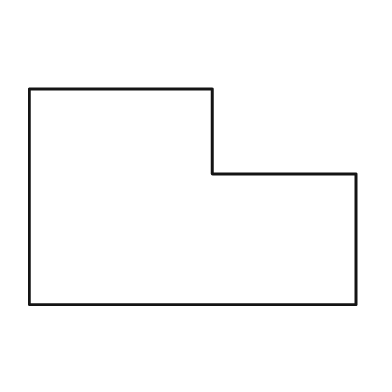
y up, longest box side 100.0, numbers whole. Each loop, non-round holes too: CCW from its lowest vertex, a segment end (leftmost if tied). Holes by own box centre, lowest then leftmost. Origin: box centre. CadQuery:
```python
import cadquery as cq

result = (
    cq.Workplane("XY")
    .moveTo(-50.0, -33.0)
    .lineTo(50.0, -33.0)
    .lineTo(50.0, 7.0)
    .lineTo(6.0, 7.0)
    .lineTo(6.0, 33.0)
    .lineTo(-50.0, 33.0)
    .close()
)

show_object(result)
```